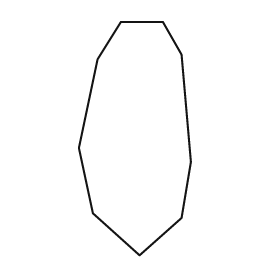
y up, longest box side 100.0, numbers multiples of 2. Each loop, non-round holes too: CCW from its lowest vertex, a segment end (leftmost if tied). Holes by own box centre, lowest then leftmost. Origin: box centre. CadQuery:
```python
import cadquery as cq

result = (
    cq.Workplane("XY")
    .moveTo(2.0, -50.0)
    .lineTo(20.0, -34.0)
    .lineTo(24.0, -10.0)
    .lineTo(20.0, 36.0)
    .lineTo(12.0, 50.0)
    .lineTo(-6.0, 50.0)
    .lineTo(-16.0, 34.0)
    .lineTo(-24.0, -4.0)
    .lineTo(-18.0, -32.0)
    .close()
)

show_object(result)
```